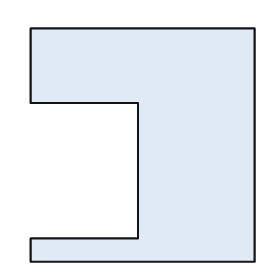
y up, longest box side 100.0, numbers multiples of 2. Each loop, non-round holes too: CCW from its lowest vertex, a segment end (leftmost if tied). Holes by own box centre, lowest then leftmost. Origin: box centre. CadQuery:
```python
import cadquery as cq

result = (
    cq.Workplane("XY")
    .moveTo(-48.0, -50.0)
    .lineTo(48.0, -50.0)
    .lineTo(48.0, 50.0)
    .lineTo(-48.0, 50.0)
    .lineTo(-48.0, 18.0)
    .lineTo(-2.0, 18.0)
    .lineTo(-2.0, -40.0)
    .lineTo(-48.0, -40.0)
    .close()
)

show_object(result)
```